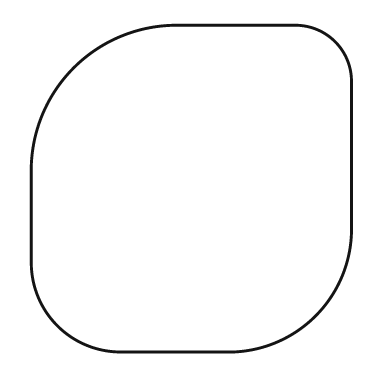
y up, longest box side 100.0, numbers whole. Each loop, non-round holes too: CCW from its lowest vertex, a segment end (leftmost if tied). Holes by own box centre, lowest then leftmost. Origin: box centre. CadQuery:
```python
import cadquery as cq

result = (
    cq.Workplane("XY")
    .moveTo(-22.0, -50.0)
    .lineTo(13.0, -50.0)
    .threePointArc((38.0, -39.0), (49.0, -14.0))
    .lineTo(49.0, 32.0)
    .threePointArc((44.0, 45.0), (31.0, 50.0))
    .lineTo(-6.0, 50.0)
    .threePointArc((-36.0, 37.0), (-49.0, 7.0))
    .lineTo(-49.0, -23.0)
    .threePointArc((-41.0, -42.0), (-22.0, -50.0))
    .close()
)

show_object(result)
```